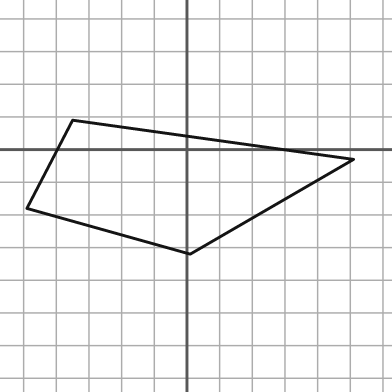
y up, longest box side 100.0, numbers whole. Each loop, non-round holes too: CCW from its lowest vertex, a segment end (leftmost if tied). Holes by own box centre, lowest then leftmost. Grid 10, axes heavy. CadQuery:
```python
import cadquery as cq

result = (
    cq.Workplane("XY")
    .moveTo(1.0, -32.0)
    .lineTo(51.0, -3.0)
    .lineTo(-35.0, 9.0)
    .lineTo(-49.0, -18.0)
    .close()
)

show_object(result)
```